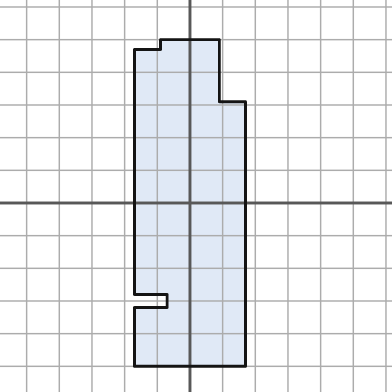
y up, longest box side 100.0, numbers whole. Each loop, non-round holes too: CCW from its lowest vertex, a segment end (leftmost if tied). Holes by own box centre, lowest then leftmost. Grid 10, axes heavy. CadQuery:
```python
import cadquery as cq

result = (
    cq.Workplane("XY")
    .moveTo(-17.0, -50.0)
    .lineTo(17.0, -50.0)
    .lineTo(17.0, 31.0)
    .lineTo(9.0, 31.0)
    .lineTo(9.0, 50.0)
    .lineTo(-9.0, 50.0)
    .lineTo(-9.0, 47.0)
    .lineTo(-17.0, 47.0)
    .lineTo(-17.0, -28.0)
    .lineTo(-7.0, -28.0)
    .lineTo(-7.0, -32.0)
    .lineTo(-17.0, -32.0)
    .close()
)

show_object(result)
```